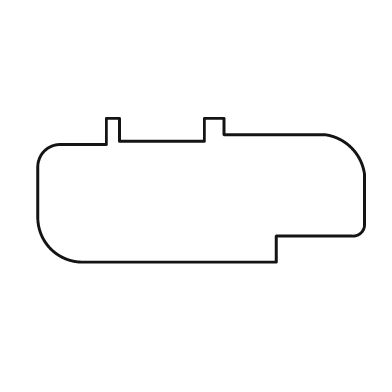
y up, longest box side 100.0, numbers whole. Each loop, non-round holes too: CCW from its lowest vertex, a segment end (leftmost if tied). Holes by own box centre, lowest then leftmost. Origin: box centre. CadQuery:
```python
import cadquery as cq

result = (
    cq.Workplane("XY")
    .moveTo(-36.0, -22.0)
    .lineTo(23.0, -22.0)
    .lineTo(23.0, -14.0)
    .lineTo(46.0, -14.0)
    .threePointArc((49.0, -13.0), (50.0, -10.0))
    .lineTo(50.0, 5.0)
    .threePointArc((46.0, 13.0), (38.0, 17.0))
    .lineTo(7.0, 17.0)
    .lineTo(7.0, 22.0)
    .lineTo(1.0, 22.0)
    .lineTo(1.0, 15.0)
    .lineTo(-25.0, 15.0)
    .lineTo(-25.0, 22.0)
    .lineTo(-29.0, 22.0)
    .lineTo(-29.0, 14.0)
    .lineTo(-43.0, 14.0)
    .threePointArc((-48.0, 12.0), (-50.0, 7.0))
    .lineTo(-50.0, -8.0)
    .threePointArc((-46.0, -18.0), (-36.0, -22.0))
    .close()
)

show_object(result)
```